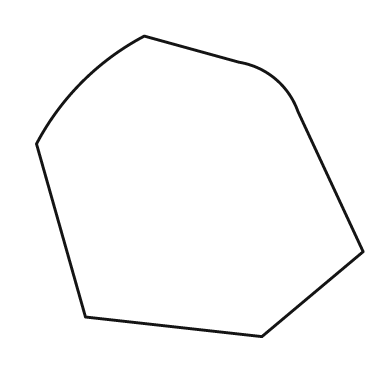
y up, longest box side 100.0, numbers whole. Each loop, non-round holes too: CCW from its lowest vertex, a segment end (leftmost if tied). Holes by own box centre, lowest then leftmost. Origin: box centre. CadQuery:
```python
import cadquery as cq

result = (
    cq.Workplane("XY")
    .moveTo(19.0, -46.0)
    .lineTo(50.0, -20.0)
    .lineTo(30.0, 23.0)
    .threePointArc((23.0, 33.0), (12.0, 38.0))
    .lineTo(-17.0, 46.0)
    .threePointArc((-36.0, 32.0), (-50.0, 13.0))
    .lineTo(-35.0, -40.0)
    .close()
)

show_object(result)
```